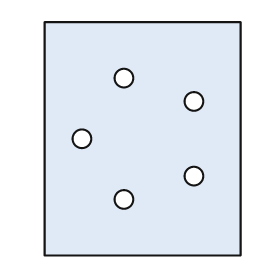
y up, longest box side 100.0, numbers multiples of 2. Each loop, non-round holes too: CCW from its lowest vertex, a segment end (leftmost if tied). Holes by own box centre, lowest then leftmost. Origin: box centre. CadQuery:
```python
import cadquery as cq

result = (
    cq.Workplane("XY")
    .moveTo(-42.0, -50.0)
    .lineTo(42.0, -50.0)
    .lineTo(42.0, 50.0)
    .lineTo(-42.0, 50.0)
    .close()
    .moveTo(-8.0, -26.0)
    .circle(4.0)
    .moveTo(22.0, -16.0)
    .circle(4.0)
    .moveTo(-26.0, 0.0)
    .circle(4.0)
    .moveTo(22.0, 16.0)
    .circle(4.0)
    .moveTo(-8.0, 26.0)
    .circle(4.0)
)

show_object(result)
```